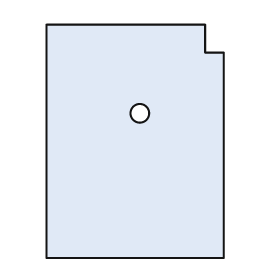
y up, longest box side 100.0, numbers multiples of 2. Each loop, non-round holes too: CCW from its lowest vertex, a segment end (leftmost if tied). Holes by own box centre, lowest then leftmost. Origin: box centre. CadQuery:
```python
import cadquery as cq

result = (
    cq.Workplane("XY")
    .moveTo(-38.0, -50.0)
    .lineTo(38.0, -50.0)
    .lineTo(38.0, 38.0)
    .lineTo(30.0, 38.0)
    .lineTo(30.0, 50.0)
    .lineTo(-38.0, 50.0)
    .close()
    .moveTo(2.0, 12.0)
    .circle(4.0)
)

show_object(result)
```